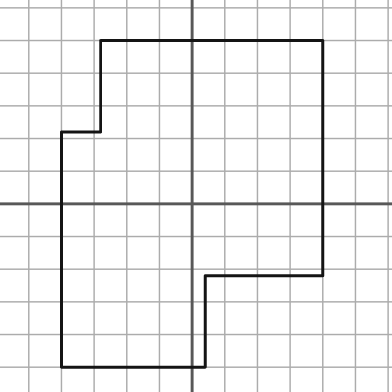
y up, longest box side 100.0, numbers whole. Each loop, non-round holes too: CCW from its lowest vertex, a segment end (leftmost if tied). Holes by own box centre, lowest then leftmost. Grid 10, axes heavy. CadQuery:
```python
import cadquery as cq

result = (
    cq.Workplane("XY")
    .moveTo(-40.0, -50.0)
    .lineTo(4.0, -50.0)
    .lineTo(4.0, -22.0)
    .lineTo(40.0, -22.0)
    .lineTo(40.0, 50.0)
    .lineTo(-28.0, 50.0)
    .lineTo(-28.0, 22.0)
    .lineTo(-40.0, 22.0)
    .close()
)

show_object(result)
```